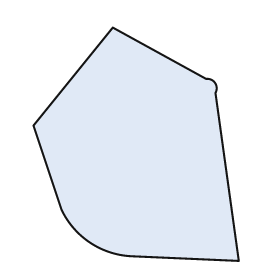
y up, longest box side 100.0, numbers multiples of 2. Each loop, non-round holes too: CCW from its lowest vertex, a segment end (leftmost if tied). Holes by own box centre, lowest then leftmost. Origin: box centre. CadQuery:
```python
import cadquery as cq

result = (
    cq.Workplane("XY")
    .moveTo(44.0, -50.0)
    .lineTo(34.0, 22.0)
    .threePointArc((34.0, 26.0), (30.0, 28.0))
    .lineTo(-10.0, 50.0)
    .lineTo(-44.0, 8.0)
    .lineTo(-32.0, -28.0)
    .threePointArc((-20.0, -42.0), (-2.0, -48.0))
    .close()
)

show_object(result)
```